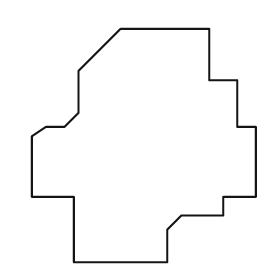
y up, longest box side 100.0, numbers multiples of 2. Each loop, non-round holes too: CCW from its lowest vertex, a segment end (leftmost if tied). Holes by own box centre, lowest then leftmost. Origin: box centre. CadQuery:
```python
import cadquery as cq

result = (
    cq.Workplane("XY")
    .moveTo(-30.0, -50.0)
    .lineTo(10.0, -50.0)
    .lineTo(10.0, -36.0)
    .lineTo(16.0, -30.0)
    .lineTo(34.0, -30.0)
    .lineTo(34.0, -22.0)
    .lineTo(48.0, -22.0)
    .lineTo(48.0, 8.0)
    .lineTo(40.0, 8.0)
    .lineTo(40.0, 28.0)
    .lineTo(28.0, 28.0)
    .lineTo(28.0, 50.0)
    .lineTo(-10.0, 50.0)
    .lineTo(-28.0, 32.0)
    .lineTo(-28.0, 14.0)
    .lineTo(-34.0, 8.0)
    .lineTo(-42.0, 8.0)
    .lineTo(-48.0, 4.0)
    .lineTo(-48.0, -22.0)
    .lineTo(-30.0, -22.0)
    .close()
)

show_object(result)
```